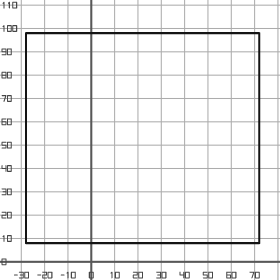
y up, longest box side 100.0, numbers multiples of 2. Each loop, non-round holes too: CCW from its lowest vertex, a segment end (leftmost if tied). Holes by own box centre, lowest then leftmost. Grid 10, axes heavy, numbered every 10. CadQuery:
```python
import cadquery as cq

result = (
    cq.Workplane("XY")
    .moveTo(-28.0, 8.0)
    .lineTo(72.0, 8.0)
    .lineTo(72.0, 98.0)
    .lineTo(-28.0, 98.0)
    .close()
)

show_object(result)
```